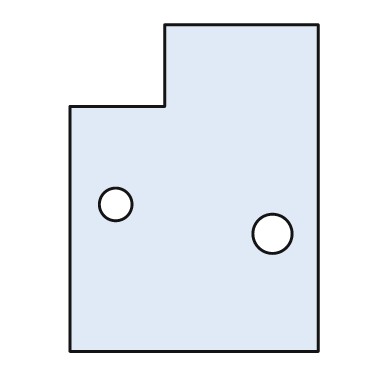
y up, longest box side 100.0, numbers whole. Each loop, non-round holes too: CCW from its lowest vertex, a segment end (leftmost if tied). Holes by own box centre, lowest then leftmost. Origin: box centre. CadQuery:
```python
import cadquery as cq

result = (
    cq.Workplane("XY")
    .moveTo(-38.0, -50.0)
    .lineTo(38.0, -50.0)
    .lineTo(38.0, 50.0)
    .lineTo(-9.0, 50.0)
    .lineTo(-9.0, 25.0)
    .lineTo(-38.0, 25.0)
    .close()
    .moveTo(24.0, -14.0)
    .circle(6.0)
    .moveTo(-24.0, -5.0)
    .circle(5.0)
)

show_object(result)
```